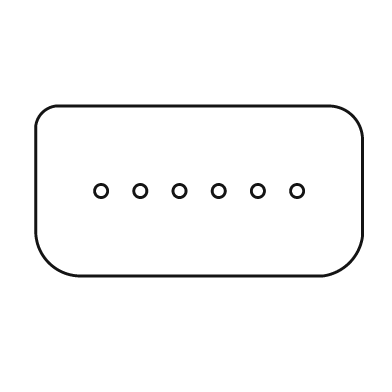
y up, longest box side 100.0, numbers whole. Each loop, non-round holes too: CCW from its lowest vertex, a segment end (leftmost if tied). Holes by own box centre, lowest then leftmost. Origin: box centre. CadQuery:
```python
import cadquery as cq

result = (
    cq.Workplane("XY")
    .moveTo(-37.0, -26.0)
    .lineTo(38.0, -26.0)
    .threePointArc((46.0, -22.0), (50.0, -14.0))
    .lineTo(50.0, 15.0)
    .threePointArc((47.0, 23.0), (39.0, 26.0))
    .lineTo(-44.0, 26.0)
    .threePointArc((-48.0, 24.0), (-50.0, 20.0))
    .lineTo(-50.0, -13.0)
    .threePointArc((-46.0, -22.0), (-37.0, -26.0))
    .close()
    .moveTo(-30.0, 0.0)
    .circle(2.0)
    .moveTo(-18.0, 0.0)
    .circle(2.0)
    .moveTo(-6.0, 0.0)
    .circle(2.0)
    .moveTo(6.0, 0.0)
    .circle(2.0)
    .moveTo(18.0, 0.0)
    .circle(2.0)
    .moveTo(30.0, 0.0)
    .circle(2.0)
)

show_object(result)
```